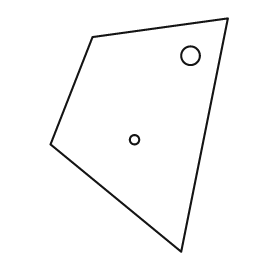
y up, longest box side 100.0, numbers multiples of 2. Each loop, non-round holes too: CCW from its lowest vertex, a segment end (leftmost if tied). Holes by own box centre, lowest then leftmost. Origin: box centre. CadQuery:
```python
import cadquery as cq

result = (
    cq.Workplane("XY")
    .moveTo(18.0, -50.0)
    .lineTo(38.0, 50.0)
    .lineTo(-20.0, 42.0)
    .lineTo(-38.0, -4.0)
    .close()
    .moveTo(-2.0, -2.0)
    .circle(2.0)
    .moveTo(22.0, 34.0)
    .circle(4.0)
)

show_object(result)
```